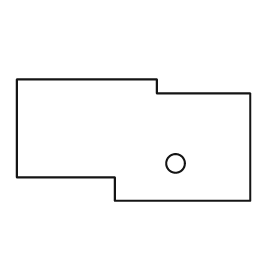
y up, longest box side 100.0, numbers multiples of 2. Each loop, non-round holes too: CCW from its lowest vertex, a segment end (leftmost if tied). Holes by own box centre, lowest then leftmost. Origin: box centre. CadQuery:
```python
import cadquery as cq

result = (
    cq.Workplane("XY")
    .moveTo(-8.0, -26.0)
    .lineTo(50.0, -26.0)
    .lineTo(50.0, 20.0)
    .lineTo(10.0, 20.0)
    .lineTo(10.0, 26.0)
    .lineTo(-50.0, 26.0)
    .lineTo(-50.0, -16.0)
    .lineTo(-8.0, -16.0)
    .close()
    .moveTo(18.0, -10.0)
    .circle(4.0)
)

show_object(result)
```